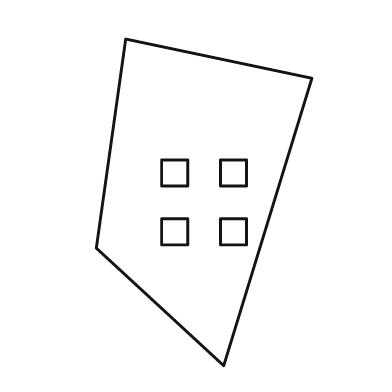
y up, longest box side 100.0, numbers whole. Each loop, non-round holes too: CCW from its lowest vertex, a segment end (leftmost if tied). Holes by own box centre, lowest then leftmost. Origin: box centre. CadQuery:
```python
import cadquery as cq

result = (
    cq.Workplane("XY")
    .moveTo(6.0, -50.0)
    .lineTo(33.0, 38.0)
    .lineTo(-24.0, 50.0)
    .lineTo(-33.0, -14.0)
    .close()
    .moveTo(-13.0, -13.0)
    .lineTo(-5.0, -13.0)
    .lineTo(-5.0, -5.0)
    .lineTo(-13.0, -5.0)
    .close()
    .moveTo(5.0, -13.0)
    .lineTo(13.0, -13.0)
    .lineTo(13.0, -5.0)
    .lineTo(5.0, -5.0)
    .close()
    .moveTo(-13.0, 5.0)
    .lineTo(-5.0, 5.0)
    .lineTo(-5.0, 13.0)
    .lineTo(-13.0, 13.0)
    .close()
    .moveTo(5.0, 5.0)
    .lineTo(13.0, 5.0)
    .lineTo(13.0, 13.0)
    .lineTo(5.0, 13.0)
    .close()
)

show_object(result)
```